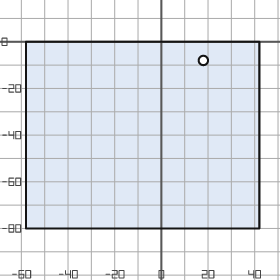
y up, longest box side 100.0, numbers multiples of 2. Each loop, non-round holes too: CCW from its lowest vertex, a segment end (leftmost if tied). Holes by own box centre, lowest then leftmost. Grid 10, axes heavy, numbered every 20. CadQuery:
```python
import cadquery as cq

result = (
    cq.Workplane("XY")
    .moveTo(-58.0, -80.0)
    .lineTo(42.0, -80.0)
    .lineTo(42.0, 0.0)
    .lineTo(-58.0, 0.0)
    .close()
    .moveTo(18.0, -8.0)
    .circle(2.0)
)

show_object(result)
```